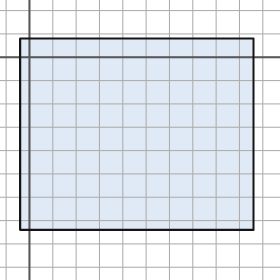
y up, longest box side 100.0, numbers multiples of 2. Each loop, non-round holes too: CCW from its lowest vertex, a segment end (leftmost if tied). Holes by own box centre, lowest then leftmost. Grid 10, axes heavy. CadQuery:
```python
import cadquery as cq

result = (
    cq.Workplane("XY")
    .moveTo(-4.0, -74.0)
    .lineTo(96.0, -74.0)
    .lineTo(96.0, 8.0)
    .lineTo(-4.0, 8.0)
    .close()
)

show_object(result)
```